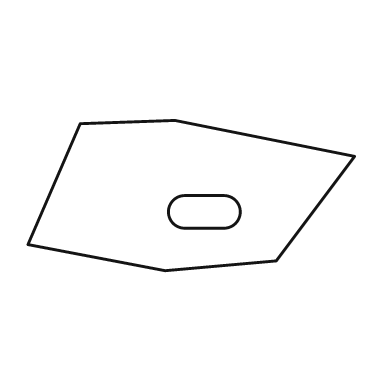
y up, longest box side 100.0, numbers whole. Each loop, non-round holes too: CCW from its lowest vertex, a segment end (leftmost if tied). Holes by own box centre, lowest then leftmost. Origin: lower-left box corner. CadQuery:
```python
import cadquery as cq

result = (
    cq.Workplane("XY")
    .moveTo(42.0, 0.0)
    .lineTo(76.0, 3.0)
    .lineTo(100.0, 35.0)
    .lineTo(45.0, 46.0)
    .lineTo(16.0, 45.0)
    .lineTo(0.0, 8.0)
    .close()
    .moveTo(48.0, 13.0)
    .lineTo(60.0, 13.0)
    .threePointArc((65.0, 18.0), (60.0, 23.0))
    .lineTo(48.0, 23.0)
    .threePointArc((43.0, 18.0), (48.0, 13.0))
    .close()
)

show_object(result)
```